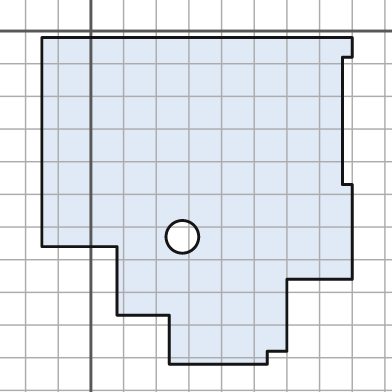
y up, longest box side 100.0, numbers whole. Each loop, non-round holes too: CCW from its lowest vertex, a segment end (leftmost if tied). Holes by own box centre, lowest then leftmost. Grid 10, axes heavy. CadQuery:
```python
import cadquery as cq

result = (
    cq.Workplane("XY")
    .moveTo(24.0, -102.0)
    .lineTo(54.0, -102.0)
    .lineTo(54.0, -98.0)
    .lineTo(60.0, -98.0)
    .lineTo(60.0, -76.0)
    .lineTo(80.0, -76.0)
    .lineTo(80.0, -47.0)
    .lineTo(77.0, -47.0)
    .lineTo(77.0, -8.0)
    .lineTo(80.0, -8.0)
    .lineTo(80.0, -2.0)
    .lineTo(-15.0, -2.0)
    .lineTo(-15.0, -66.0)
    .lineTo(8.0, -66.0)
    .lineTo(8.0, -87.0)
    .lineTo(24.0, -87.0)
    .close()
    .moveTo(28.0, -63.0)
    .circle(5.0)
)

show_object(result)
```